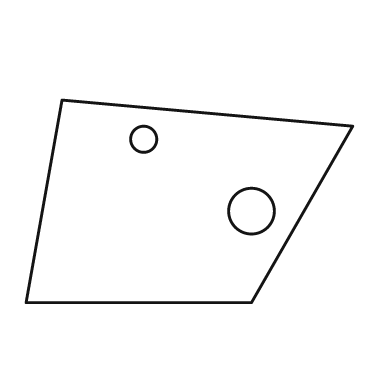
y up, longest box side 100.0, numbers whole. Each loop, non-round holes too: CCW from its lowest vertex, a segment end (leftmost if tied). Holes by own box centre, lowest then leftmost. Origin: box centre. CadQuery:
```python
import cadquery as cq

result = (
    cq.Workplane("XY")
    .moveTo(-50.0, -31.0)
    .lineTo(19.0, -31.0)
    .lineTo(50.0, 23.0)
    .lineTo(-39.0, 31.0)
    .close()
    .moveTo(19.0, -3.0)
    .circle(7.0)
    .moveTo(-14.0, 19.0)
    .circle(4.0)
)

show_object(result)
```